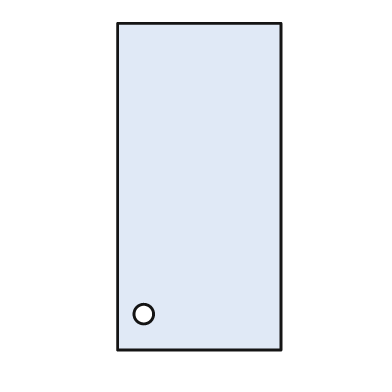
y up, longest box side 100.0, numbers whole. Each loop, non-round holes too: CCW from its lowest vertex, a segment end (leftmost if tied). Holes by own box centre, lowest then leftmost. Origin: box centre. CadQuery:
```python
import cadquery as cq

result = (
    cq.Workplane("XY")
    .moveTo(-25.0, -50.0)
    .lineTo(25.0, -50.0)
    .lineTo(25.0, 50.0)
    .lineTo(-25.0, 50.0)
    .close()
    .moveTo(-17.0, -39.0)
    .circle(3.0)
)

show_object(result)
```